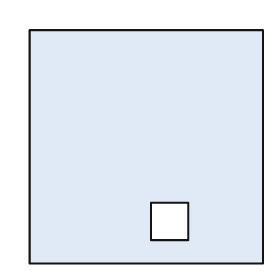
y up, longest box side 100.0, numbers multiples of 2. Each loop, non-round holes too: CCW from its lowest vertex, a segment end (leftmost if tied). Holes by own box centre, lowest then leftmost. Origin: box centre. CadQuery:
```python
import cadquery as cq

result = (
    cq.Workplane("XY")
    .moveTo(-50.0, -50.0)
    .lineTo(50.0, -50.0)
    .lineTo(50.0, 50.0)
    .lineTo(-50.0, 50.0)
    .close()
    .moveTo(2.0, -40.0)
    .lineTo(18.0, -40.0)
    .lineTo(18.0, -24.0)
    .lineTo(2.0, -24.0)
    .close()
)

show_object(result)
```